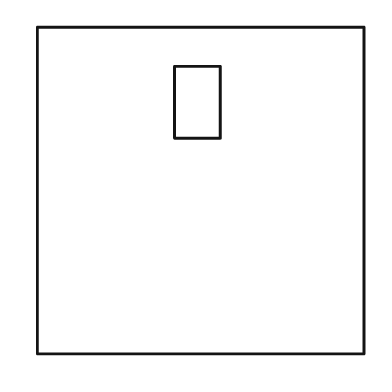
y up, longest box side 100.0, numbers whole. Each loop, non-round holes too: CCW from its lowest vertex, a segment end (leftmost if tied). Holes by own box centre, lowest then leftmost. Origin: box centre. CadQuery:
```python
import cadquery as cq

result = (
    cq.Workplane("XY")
    .moveTo(-50.0, -50.0)
    .lineTo(50.0, -50.0)
    .lineTo(50.0, 50.0)
    .lineTo(-50.0, 50.0)
    .close()
    .moveTo(-8.0, 16.0)
    .lineTo(6.0, 16.0)
    .lineTo(6.0, 38.0)
    .lineTo(-8.0, 38.0)
    .close()
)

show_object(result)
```